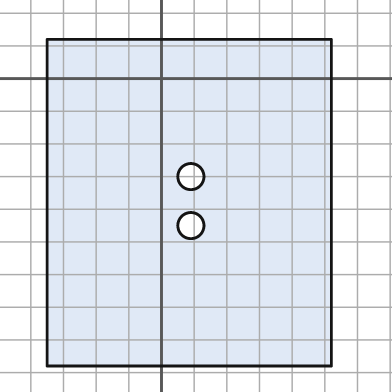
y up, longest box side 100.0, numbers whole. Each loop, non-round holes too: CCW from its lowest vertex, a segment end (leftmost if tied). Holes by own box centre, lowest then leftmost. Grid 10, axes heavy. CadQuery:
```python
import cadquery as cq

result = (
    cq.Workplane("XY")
    .moveTo(-35.0, -88.0)
    .lineTo(52.0, -88.0)
    .lineTo(52.0, 12.0)
    .lineTo(-35.0, 12.0)
    .close()
    .moveTo(9.0, -45.0)
    .circle(4.0)
    .moveTo(9.0, -30.0)
    .circle(4.0)
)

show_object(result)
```